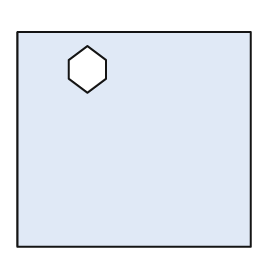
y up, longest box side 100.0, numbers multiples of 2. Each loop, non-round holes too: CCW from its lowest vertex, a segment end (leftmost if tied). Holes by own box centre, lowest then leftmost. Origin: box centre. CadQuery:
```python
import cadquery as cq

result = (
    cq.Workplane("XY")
    .moveTo(-50.0, -46.0)
    .lineTo(50.0, -46.0)
    .lineTo(50.0, 46.0)
    .lineTo(-50.0, 46.0)
    .close()
    .moveTo(-20.0, 20.0)
    .lineTo(-12.0, 26.0)
    .lineTo(-12.0, 34.0)
    .lineTo(-20.0, 40.0)
    .lineTo(-28.0, 34.0)
    .lineTo(-28.0, 26.0)
    .close()
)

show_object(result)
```